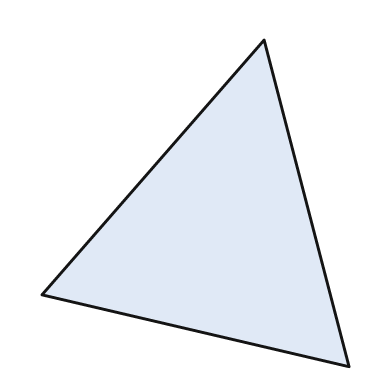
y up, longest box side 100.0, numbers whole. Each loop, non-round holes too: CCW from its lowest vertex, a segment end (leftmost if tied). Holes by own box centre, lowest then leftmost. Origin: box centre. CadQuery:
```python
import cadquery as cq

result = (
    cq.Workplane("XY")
    .moveTo(47.0, -50.0)
    .lineTo(21.0, 50.0)
    .lineTo(-47.0, -28.0)
    .close()
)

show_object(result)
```